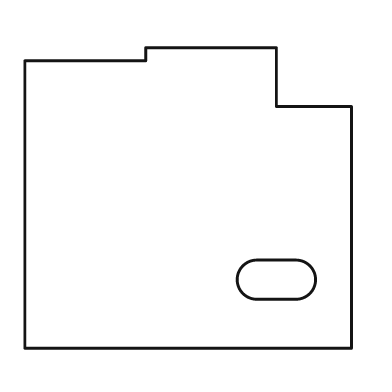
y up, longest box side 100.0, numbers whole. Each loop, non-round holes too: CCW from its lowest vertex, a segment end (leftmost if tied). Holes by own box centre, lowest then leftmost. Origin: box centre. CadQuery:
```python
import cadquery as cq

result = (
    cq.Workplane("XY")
    .moveTo(-50.0, -46.0)
    .lineTo(50.0, -46.0)
    .lineTo(50.0, 28.0)
    .lineTo(27.0, 28.0)
    .lineTo(27.0, 46.0)
    .lineTo(-13.0, 46.0)
    .lineTo(-13.0, 42.0)
    .lineTo(-50.0, 42.0)
    .close()
    .moveTo(21.0, -31.0)
    .lineTo(33.0, -31.0)
    .threePointArc((39.0, -25.0), (33.0, -19.0))
    .lineTo(21.0, -19.0)
    .threePointArc((15.0, -25.0), (21.0, -31.0))
    .close()
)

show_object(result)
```